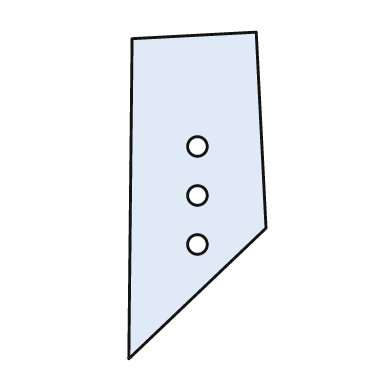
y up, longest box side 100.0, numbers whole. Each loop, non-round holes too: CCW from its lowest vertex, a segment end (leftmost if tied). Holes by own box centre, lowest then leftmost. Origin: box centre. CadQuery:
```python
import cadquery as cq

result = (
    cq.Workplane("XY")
    .moveTo(-21.0, -50.0)
    .lineTo(21.0, -10.0)
    .lineTo(18.0, 50.0)
    .lineTo(-20.0, 48.0)
    .close()
    .moveTo(0.0, -15.0)
    .circle(3.0)
    .moveTo(0.0, 0.0)
    .circle(3.0)
    .moveTo(0.0, 15.0)
    .circle(3.0)
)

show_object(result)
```